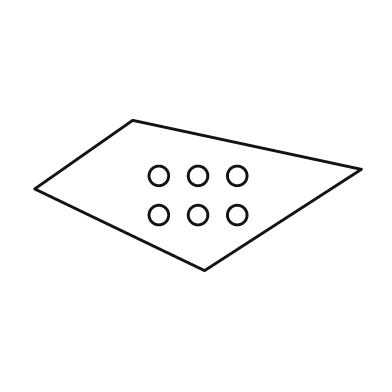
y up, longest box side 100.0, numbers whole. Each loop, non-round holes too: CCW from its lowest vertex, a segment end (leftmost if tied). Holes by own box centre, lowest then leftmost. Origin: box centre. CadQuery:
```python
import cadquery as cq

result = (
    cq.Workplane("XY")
    .moveTo(2.0, -23.0)
    .lineTo(50.0, 8.0)
    .lineTo(-20.0, 23.0)
    .lineTo(-50.0, 2.0)
    .close()
    .moveTo(-12.0, -6.0)
    .circle(3.0)
    .moveTo(0.0, -6.0)
    .circle(3.0)
    .moveTo(12.0, -6.0)
    .circle(3.0)
    .moveTo(-12.0, 6.0)
    .circle(3.0)
    .moveTo(0.0, 6.0)
    .circle(3.0)
    .moveTo(12.0, 6.0)
    .circle(3.0)
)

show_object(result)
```